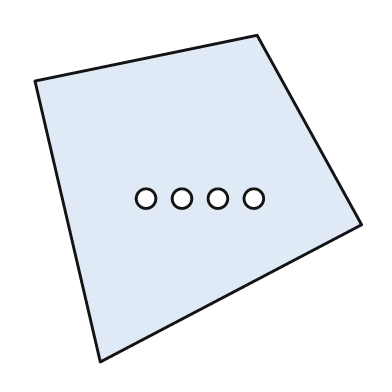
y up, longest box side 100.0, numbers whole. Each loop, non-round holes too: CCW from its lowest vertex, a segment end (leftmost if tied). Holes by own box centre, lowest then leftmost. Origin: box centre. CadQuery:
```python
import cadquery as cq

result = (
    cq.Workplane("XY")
    .moveTo(-30.0, -50.0)
    .lineTo(50.0, -8.0)
    .lineTo(18.0, 50.0)
    .lineTo(-50.0, 36.0)
    .close()
    .moveTo(-16.0, 0.0)
    .circle(3.0)
    .moveTo(-5.0, 0.0)
    .circle(3.0)
    .moveTo(6.0, 0.0)
    .circle(3.0)
    .moveTo(17.0, 0.0)
    .circle(3.0)
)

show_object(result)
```